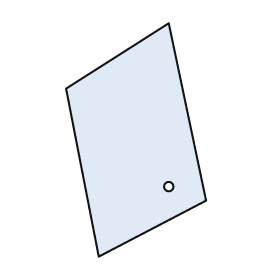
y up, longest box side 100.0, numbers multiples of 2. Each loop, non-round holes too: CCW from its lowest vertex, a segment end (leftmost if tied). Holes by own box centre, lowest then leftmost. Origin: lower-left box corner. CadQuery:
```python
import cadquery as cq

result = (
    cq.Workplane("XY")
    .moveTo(14.0, 0.0)
    .lineTo(60.0, 24.0)
    .lineTo(44.0, 100.0)
    .lineTo(0.0, 72.0)
    .close()
    .moveTo(44.0, 30.0)
    .circle(2.0)
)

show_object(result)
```